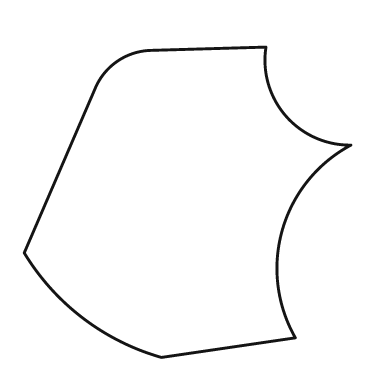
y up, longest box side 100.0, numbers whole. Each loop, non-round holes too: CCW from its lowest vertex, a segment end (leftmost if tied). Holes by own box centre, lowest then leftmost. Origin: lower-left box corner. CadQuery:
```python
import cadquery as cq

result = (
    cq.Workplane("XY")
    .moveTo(42.0, 0.0)
    .lineTo(83.0, 6.0)
    .threePointArc((79.0, 39.0), (100.0, 65.0))
    .threePointArc((80.0, 74.0), (74.0, 95.0))
    .lineTo(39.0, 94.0)
    .threePointArc((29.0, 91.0), (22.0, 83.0))
    .lineTo(0.0, 32.0)
    .threePointArc((18.0, 12.0), (42.0, 0.0))
    .close()
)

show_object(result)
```